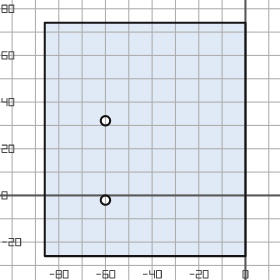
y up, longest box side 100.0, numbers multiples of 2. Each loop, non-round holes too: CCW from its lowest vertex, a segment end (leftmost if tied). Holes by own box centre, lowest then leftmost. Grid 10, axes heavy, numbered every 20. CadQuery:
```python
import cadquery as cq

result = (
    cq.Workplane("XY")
    .moveTo(-86.0, -26.0)
    .lineTo(0.0, -26.0)
    .lineTo(0.0, 74.0)
    .lineTo(-86.0, 74.0)
    .close()
    .moveTo(-60.0, -2.0)
    .circle(2.0)
    .moveTo(-60.0, 32.0)
    .circle(2.0)
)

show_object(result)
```